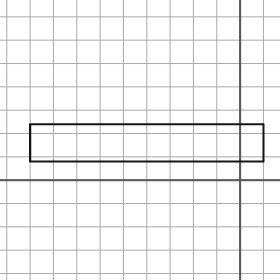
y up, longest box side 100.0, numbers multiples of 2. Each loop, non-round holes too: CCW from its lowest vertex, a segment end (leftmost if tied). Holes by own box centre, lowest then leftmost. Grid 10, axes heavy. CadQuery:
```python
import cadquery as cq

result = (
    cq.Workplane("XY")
    .moveTo(-90.0, 8.0)
    .lineTo(10.0, 8.0)
    .lineTo(10.0, 24.0)
    .lineTo(-90.0, 24.0)
    .close()
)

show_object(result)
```